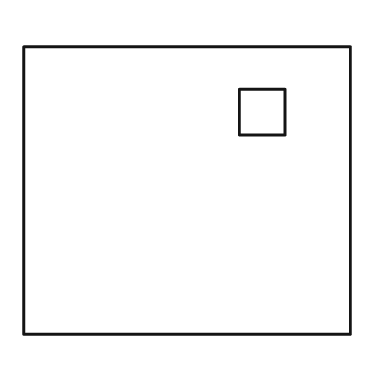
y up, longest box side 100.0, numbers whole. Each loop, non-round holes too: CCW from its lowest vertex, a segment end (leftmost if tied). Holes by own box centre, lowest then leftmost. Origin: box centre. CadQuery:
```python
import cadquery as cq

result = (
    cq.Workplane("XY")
    .moveTo(-50.0, -44.0)
    .lineTo(50.0, -44.0)
    .lineTo(50.0, 44.0)
    .lineTo(-50.0, 44.0)
    .close()
    .moveTo(16.0, 17.0)
    .lineTo(30.0, 17.0)
    .lineTo(30.0, 31.0)
    .lineTo(16.0, 31.0)
    .close()
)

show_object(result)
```